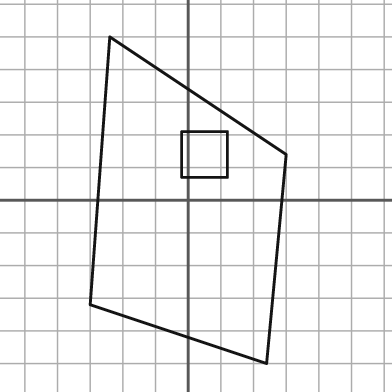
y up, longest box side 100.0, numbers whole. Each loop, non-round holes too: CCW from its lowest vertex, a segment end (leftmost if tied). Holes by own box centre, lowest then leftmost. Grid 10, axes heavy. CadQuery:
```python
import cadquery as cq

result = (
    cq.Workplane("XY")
    .moveTo(24.0, -50.0)
    .lineTo(30.0, 14.0)
    .lineTo(-24.0, 50.0)
    .lineTo(-30.0, -32.0)
    .close()
    .moveTo(-2.0, 7.0)
    .lineTo(12.0, 7.0)
    .lineTo(12.0, 21.0)
    .lineTo(-2.0, 21.0)
    .close()
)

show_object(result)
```